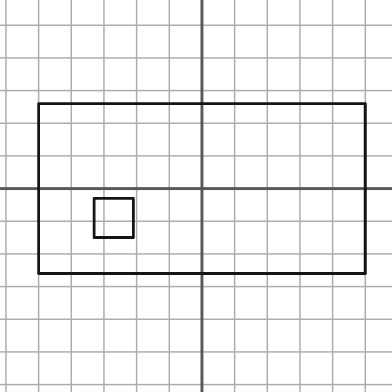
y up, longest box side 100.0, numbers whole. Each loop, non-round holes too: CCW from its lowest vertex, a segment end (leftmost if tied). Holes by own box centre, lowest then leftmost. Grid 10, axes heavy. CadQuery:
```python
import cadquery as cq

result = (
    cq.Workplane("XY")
    .moveTo(-50.0, -26.0)
    .lineTo(50.0, -26.0)
    .lineTo(50.0, 26.0)
    .lineTo(-50.0, 26.0)
    .close()
    .moveTo(-33.0, -15.0)
    .lineTo(-21.0, -15.0)
    .lineTo(-21.0, -3.0)
    .lineTo(-33.0, -3.0)
    .close()
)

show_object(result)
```